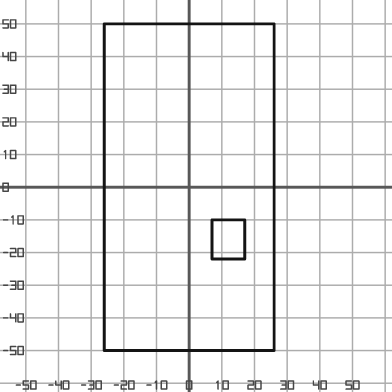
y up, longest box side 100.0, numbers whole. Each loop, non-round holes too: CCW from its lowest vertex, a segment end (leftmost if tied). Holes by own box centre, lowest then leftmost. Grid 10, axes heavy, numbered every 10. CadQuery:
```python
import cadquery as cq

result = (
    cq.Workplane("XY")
    .moveTo(-26.0, -50.0)
    .lineTo(26.0, -50.0)
    .lineTo(26.0, 50.0)
    .lineTo(-26.0, 50.0)
    .close()
    .moveTo(7.0, -22.0)
    .lineTo(17.0, -22.0)
    .lineTo(17.0, -10.0)
    .lineTo(7.0, -10.0)
    .close()
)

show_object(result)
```